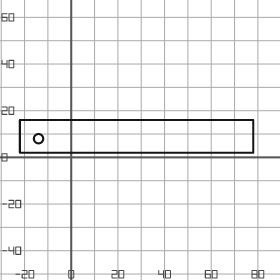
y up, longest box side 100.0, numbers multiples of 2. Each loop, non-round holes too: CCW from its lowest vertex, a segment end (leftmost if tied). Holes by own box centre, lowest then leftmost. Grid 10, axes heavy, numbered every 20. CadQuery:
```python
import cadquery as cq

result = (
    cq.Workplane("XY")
    .moveTo(-22.0, 2.0)
    .lineTo(78.0, 2.0)
    .lineTo(78.0, 16.0)
    .lineTo(-22.0, 16.0)
    .close()
    .moveTo(-14.0, 8.0)
    .circle(2.0)
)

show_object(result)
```